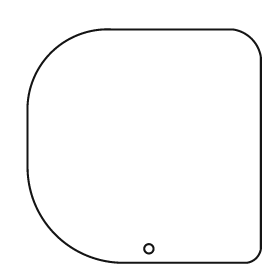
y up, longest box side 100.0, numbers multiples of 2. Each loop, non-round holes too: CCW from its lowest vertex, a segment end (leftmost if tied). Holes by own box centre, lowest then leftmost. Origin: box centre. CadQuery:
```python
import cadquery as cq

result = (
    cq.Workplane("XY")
    .moveTo(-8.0, -50.0)
    .lineTo(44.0, -50.0)
    .threePointArc((48.0, -48.0), (50.0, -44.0))
    .lineTo(50.0, 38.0)
    .threePointArc((46.0, 46.0), (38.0, 50.0))
    .lineTo(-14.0, 50.0)
    .threePointArc((-40.0, 40.0), (-50.0, 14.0))
    .lineTo(-50.0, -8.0)
    .threePointArc((-38.0, -38.0), (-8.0, -50.0))
    .close()
    .moveTo(2.0, -44.0)
    .circle(2.0)
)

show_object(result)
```